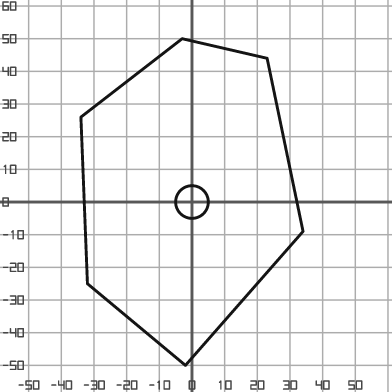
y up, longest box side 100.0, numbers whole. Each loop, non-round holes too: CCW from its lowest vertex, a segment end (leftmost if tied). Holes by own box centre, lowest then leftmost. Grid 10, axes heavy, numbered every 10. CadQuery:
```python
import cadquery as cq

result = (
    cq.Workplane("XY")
    .moveTo(-2.0, -50.0)
    .lineTo(34.0, -9.0)
    .lineTo(23.0, 44.0)
    .lineTo(-3.0, 50.0)
    .lineTo(-34.0, 26.0)
    .lineTo(-32.0, -25.0)
    .close()
    .moveTo(0.0, 0.0)
    .circle(5.0)
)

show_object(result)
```